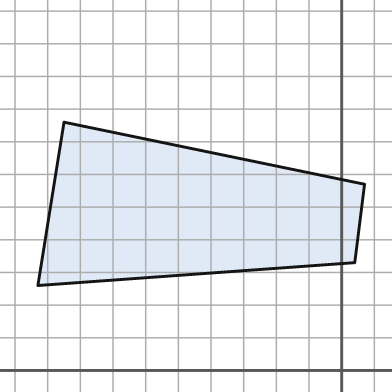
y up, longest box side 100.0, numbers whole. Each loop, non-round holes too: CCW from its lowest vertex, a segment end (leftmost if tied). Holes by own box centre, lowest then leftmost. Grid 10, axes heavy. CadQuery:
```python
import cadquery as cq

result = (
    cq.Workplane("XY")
    .moveTo(-93.0, 26.0)
    .lineTo(4.0, 33.0)
    .lineTo(7.0, 57.0)
    .lineTo(-85.0, 76.0)
    .close()
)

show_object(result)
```